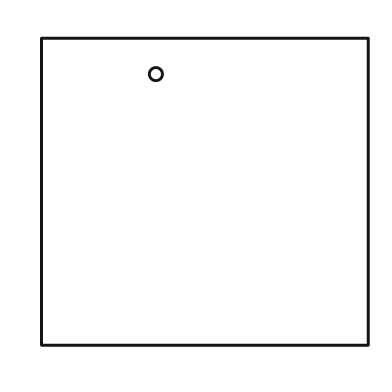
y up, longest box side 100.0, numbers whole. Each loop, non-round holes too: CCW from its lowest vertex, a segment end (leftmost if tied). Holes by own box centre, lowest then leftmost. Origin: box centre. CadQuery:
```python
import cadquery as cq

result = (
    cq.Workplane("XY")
    .moveTo(-50.0, -47.0)
    .lineTo(50.0, -47.0)
    .lineTo(50.0, 47.0)
    .lineTo(-50.0, 47.0)
    .close()
    .moveTo(-15.0, 36.0)
    .circle(2.0)
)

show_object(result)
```